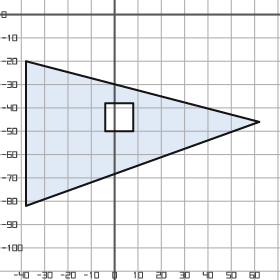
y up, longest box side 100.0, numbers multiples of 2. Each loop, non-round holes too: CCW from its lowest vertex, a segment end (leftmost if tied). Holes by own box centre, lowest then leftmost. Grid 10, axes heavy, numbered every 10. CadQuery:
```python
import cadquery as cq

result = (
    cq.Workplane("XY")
    .moveTo(-38.0, -82.0)
    .lineTo(62.0, -46.0)
    .lineTo(-38.0, -20.0)
    .close()
    .moveTo(-4.0, -50.0)
    .lineTo(8.0, -50.0)
    .lineTo(8.0, -38.0)
    .lineTo(-4.0, -38.0)
    .close()
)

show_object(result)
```